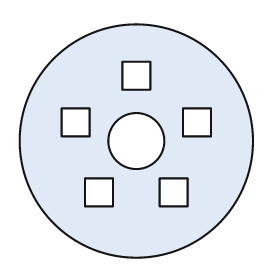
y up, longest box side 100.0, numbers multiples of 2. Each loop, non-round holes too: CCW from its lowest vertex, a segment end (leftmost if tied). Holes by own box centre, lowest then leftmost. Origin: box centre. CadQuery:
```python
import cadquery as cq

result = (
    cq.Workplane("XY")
    .moveTo(0.0, 0.0)
    .circle(50.0)
    .moveTo(-22.0, -28.0)
    .lineTo(-10.0, -28.0)
    .lineTo(-10.0, -16.0)
    .lineTo(-22.0, -16.0)
    .close()
    .moveTo(10.0, -28.0)
    .lineTo(22.0, -28.0)
    .lineTo(22.0, -16.0)
    .lineTo(10.0, -16.0)
    .close()
    .moveTo(0.0, 0.0)
    .circle(12.0)
    .moveTo(-32.0, 2.0)
    .lineTo(-20.0, 2.0)
    .lineTo(-20.0, 14.0)
    .lineTo(-32.0, 14.0)
    .close()
    .moveTo(20.0, 2.0)
    .lineTo(32.0, 2.0)
    .lineTo(32.0, 14.0)
    .lineTo(20.0, 14.0)
    .close()
    .moveTo(-6.0, 22.0)
    .lineTo(6.0, 22.0)
    .lineTo(6.0, 34.0)
    .lineTo(-6.0, 34.0)
    .close()
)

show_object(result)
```